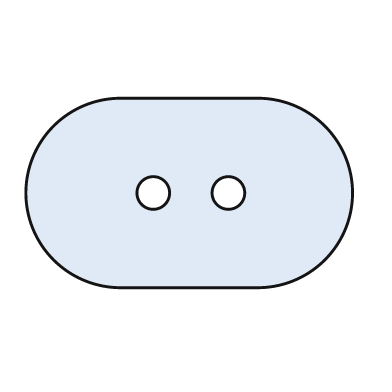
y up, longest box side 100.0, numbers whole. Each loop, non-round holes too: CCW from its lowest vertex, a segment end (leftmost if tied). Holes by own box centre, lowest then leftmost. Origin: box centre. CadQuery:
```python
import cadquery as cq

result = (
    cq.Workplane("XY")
    .moveTo(-21.0, -29.0)
    .lineTo(21.0, -29.0)
    .threePointArc((50.0, 0.0), (21.0, 29.0))
    .lineTo(-21.0, 29.0)
    .threePointArc((-50.0, 0.0), (-21.0, -29.0))
    .close()
    .moveTo(-11.0, 0.0)
    .circle(5.0)
    .moveTo(12.0, 0.0)
    .circle(5.0)
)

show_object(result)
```